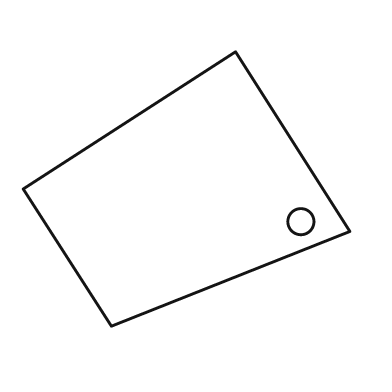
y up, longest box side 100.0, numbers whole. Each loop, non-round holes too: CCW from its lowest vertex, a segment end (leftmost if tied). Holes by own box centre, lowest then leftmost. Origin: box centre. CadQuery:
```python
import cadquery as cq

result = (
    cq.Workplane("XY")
    .moveTo(-23.0, -42.0)
    .lineTo(50.0, -13.0)
    .lineTo(15.0, 42.0)
    .lineTo(-50.0, 0.0)
    .close()
    .moveTo(35.0, -10.0)
    .circle(4.0)
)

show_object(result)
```